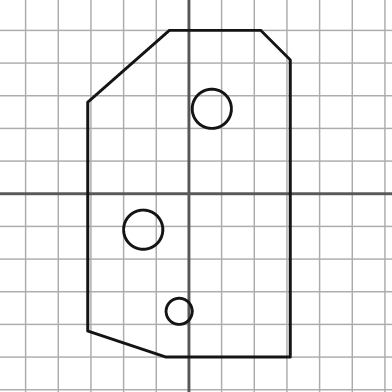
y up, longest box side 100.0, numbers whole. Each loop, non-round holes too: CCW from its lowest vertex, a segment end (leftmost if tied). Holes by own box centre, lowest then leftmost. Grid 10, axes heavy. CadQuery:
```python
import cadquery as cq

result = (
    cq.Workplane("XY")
    .moveTo(-7.0, -50.0)
    .lineTo(31.0, -50.0)
    .lineTo(31.0, 41.0)
    .lineTo(22.0, 50.0)
    .lineTo(-6.0, 50.0)
    .lineTo(-31.0, 28.0)
    .lineTo(-31.0, -42.0)
    .close()
    .moveTo(-3.0, -36.0)
    .circle(4.0)
    .moveTo(-14.0, -11.0)
    .circle(6.0)
    .moveTo(7.0, 26.0)
    .circle(6.0)
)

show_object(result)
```